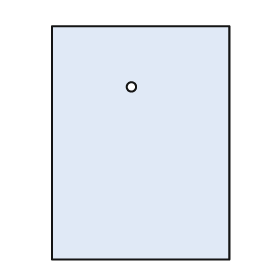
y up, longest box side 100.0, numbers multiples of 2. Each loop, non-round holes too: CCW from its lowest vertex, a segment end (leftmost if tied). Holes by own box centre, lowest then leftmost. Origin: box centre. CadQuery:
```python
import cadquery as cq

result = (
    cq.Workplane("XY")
    .moveTo(-38.0, -50.0)
    .lineTo(38.0, -50.0)
    .lineTo(38.0, 50.0)
    .lineTo(-38.0, 50.0)
    .close()
    .moveTo(-4.0, 24.0)
    .circle(2.0)
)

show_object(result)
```